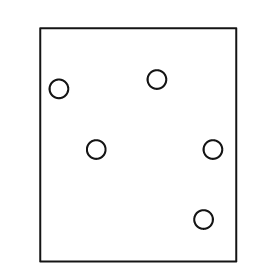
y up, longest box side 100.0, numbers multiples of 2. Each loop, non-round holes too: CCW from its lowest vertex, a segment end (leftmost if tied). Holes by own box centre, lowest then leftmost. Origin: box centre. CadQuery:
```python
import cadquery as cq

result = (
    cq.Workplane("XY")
    .moveTo(-42.0, -50.0)
    .lineTo(42.0, -50.0)
    .lineTo(42.0, 50.0)
    .lineTo(-42.0, 50.0)
    .close()
    .moveTo(28.0, -32.0)
    .circle(4.0)
    .moveTo(-18.0, -2.0)
    .circle(4.0)
    .moveTo(32.0, -2.0)
    .circle(4.0)
    .moveTo(-34.0, 24.0)
    .circle(4.0)
    .moveTo(8.0, 28.0)
    .circle(4.0)
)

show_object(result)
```